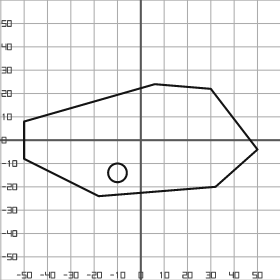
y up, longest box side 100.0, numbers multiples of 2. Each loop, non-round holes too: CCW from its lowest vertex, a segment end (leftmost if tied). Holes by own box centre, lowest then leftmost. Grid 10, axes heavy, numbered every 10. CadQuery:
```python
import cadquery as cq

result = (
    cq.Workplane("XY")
    .moveTo(-18.0, -24.0)
    .lineTo(32.0, -20.0)
    .lineTo(50.0, -4.0)
    .lineTo(30.0, 22.0)
    .lineTo(6.0, 24.0)
    .lineTo(-50.0, 8.0)
    .lineTo(-50.0, -8.0)
    .close()
    .moveTo(-10.0, -14.0)
    .circle(4.0)
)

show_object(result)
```